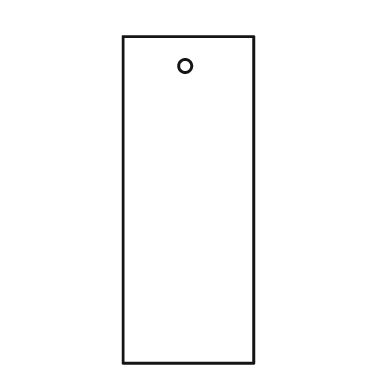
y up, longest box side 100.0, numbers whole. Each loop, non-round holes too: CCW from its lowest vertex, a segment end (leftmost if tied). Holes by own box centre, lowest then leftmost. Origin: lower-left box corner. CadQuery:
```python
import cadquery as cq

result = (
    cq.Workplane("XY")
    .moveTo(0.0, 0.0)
    .lineTo(40.0, 0.0)
    .lineTo(40.0, 100.0)
    .lineTo(0.0, 100.0)
    .close()
    .moveTo(19.0, 91.0)
    .circle(2.0)
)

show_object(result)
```